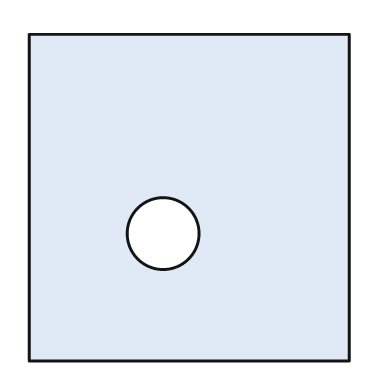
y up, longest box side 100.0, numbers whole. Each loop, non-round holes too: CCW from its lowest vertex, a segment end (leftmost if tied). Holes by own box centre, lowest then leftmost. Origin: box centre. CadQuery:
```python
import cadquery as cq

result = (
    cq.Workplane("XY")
    .moveTo(-49.0, -50.0)
    .lineTo(49.0, -50.0)
    .lineTo(49.0, 50.0)
    .lineTo(-49.0, 50.0)
    .close()
    .moveTo(-8.0, -11.0)
    .circle(11.0)
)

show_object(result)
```